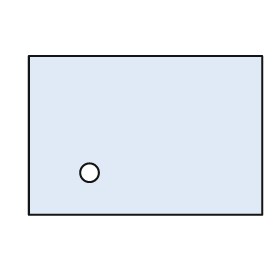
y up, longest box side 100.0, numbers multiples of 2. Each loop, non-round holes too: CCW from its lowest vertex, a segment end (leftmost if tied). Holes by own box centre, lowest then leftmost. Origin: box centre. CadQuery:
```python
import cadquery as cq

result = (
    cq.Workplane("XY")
    .moveTo(-50.0, -34.0)
    .lineTo(50.0, -34.0)
    .lineTo(50.0, 34.0)
    .lineTo(-50.0, 34.0)
    .close()
    .moveTo(-24.0, -16.0)
    .circle(4.0)
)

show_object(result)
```